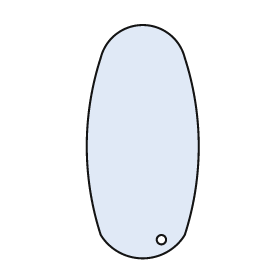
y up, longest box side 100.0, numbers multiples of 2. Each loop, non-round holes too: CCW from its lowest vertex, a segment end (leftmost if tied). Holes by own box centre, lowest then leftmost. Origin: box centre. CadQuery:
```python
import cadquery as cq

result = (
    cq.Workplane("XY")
    .moveTo(-18.0, -40.0)
    .threePointArc((0.0, -50.0), (18.0, -40.0))
    .threePointArc((24.0, -2.0), (18.0, 36.0))
    .threePointArc((0.0, 50.0), (-18.0, 36.0))
    .threePointArc((-24.0, -2.0), (-18.0, -40.0))
    .close()
    .moveTo(8.0, -42.0)
    .circle(2.0)
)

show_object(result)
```